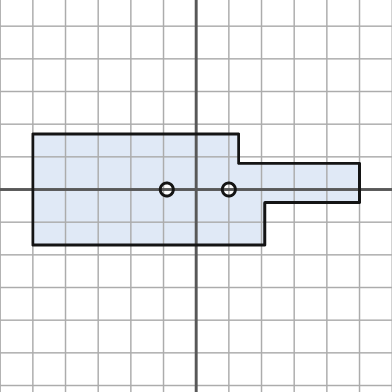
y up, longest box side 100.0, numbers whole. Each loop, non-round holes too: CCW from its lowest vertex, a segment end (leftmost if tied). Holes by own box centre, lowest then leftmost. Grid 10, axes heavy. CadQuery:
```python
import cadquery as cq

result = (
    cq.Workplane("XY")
    .moveTo(-50.0, -17.0)
    .lineTo(21.0, -17.0)
    .lineTo(21.0, -4.0)
    .lineTo(50.0, -4.0)
    .lineTo(50.0, 8.0)
    .lineTo(13.0, 8.0)
    .lineTo(13.0, 17.0)
    .lineTo(-50.0, 17.0)
    .close()
    .moveTo(-9.0, 0.0)
    .circle(2.0)
    .moveTo(10.0, 0.0)
    .circle(2.0)
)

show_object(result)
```